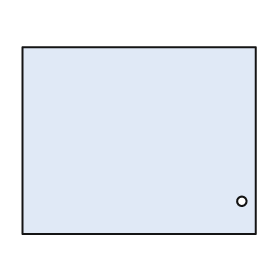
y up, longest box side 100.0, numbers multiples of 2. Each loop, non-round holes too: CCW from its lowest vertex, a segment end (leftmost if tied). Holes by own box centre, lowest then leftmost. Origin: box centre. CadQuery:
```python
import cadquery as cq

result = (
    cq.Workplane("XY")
    .moveTo(-50.0, -40.0)
    .lineTo(50.0, -40.0)
    .lineTo(50.0, 40.0)
    .lineTo(-50.0, 40.0)
    .close()
    .moveTo(44.0, -26.0)
    .circle(2.0)
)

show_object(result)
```